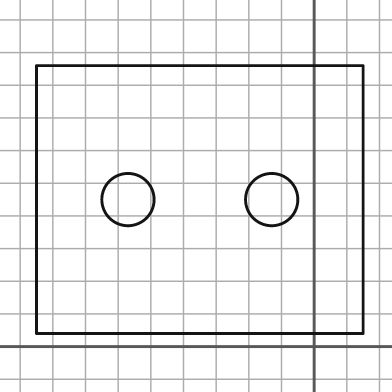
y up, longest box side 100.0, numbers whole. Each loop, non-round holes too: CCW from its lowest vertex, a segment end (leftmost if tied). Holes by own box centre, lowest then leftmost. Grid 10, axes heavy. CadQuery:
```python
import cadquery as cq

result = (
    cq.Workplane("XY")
    .moveTo(-85.0, 4.0)
    .lineTo(15.0, 4.0)
    .lineTo(15.0, 86.0)
    .lineTo(-85.0, 86.0)
    .close()
    .moveTo(-57.0, 45.0)
    .circle(8.0)
    .moveTo(-13.0, 45.0)
    .circle(8.0)
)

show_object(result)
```